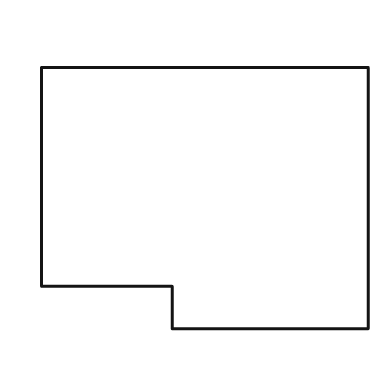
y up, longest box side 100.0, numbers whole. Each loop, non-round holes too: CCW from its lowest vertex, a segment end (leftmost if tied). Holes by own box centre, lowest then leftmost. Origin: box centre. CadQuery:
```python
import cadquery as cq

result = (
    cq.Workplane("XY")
    .moveTo(-10.0, -40.0)
    .lineTo(50.0, -40.0)
    .lineTo(50.0, 40.0)
    .lineTo(-50.0, 40.0)
    .lineTo(-50.0, -27.0)
    .lineTo(-10.0, -27.0)
    .close()
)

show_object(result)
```